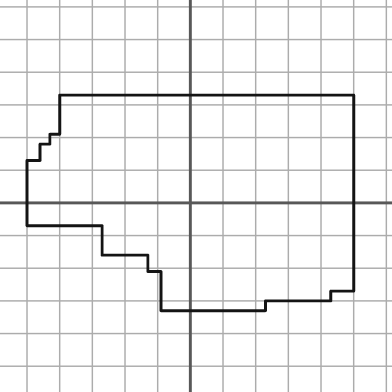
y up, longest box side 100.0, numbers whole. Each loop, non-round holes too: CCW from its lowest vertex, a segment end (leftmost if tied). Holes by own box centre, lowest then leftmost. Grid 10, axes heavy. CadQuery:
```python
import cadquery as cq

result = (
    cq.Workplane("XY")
    .moveTo(-9.0, -33.0)
    .lineTo(23.0, -33.0)
    .lineTo(23.0, -30.0)
    .lineTo(43.0, -30.0)
    .lineTo(43.0, -27.0)
    .lineTo(50.0, -27.0)
    .lineTo(50.0, 33.0)
    .lineTo(-40.0, 33.0)
    .lineTo(-40.0, 21.0)
    .lineTo(-43.0, 21.0)
    .lineTo(-43.0, 18.0)
    .lineTo(-46.0, 18.0)
    .lineTo(-46.0, 13.0)
    .lineTo(-50.0, 13.0)
    .lineTo(-50.0, -7.0)
    .lineTo(-27.0, -7.0)
    .lineTo(-27.0, -16.0)
    .lineTo(-13.0, -16.0)
    .lineTo(-13.0, -21.0)
    .lineTo(-9.0, -21.0)
    .close()
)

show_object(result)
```